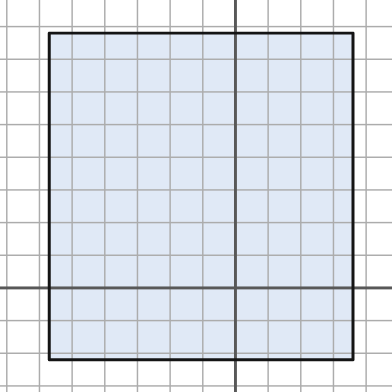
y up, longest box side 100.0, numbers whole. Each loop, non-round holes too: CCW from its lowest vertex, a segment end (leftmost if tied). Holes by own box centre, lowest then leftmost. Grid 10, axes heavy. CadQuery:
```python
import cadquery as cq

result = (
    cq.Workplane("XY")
    .moveTo(-57.0, -22.0)
    .lineTo(36.0, -22.0)
    .lineTo(36.0, 78.0)
    .lineTo(-57.0, 78.0)
    .close()
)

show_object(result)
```